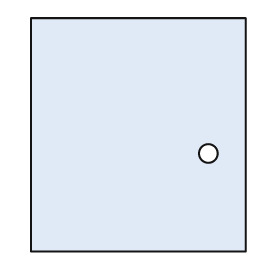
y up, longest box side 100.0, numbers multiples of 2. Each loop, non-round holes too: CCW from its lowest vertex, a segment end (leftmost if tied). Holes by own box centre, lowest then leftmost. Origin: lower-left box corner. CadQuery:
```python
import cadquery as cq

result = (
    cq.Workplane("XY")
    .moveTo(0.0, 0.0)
    .lineTo(92.0, 0.0)
    .lineTo(92.0, 100.0)
    .lineTo(0.0, 100.0)
    .close()
    .moveTo(76.0, 42.0)
    .circle(4.0)
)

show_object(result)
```